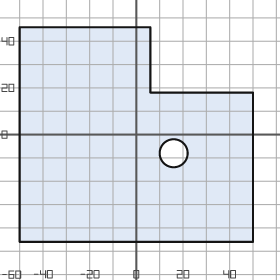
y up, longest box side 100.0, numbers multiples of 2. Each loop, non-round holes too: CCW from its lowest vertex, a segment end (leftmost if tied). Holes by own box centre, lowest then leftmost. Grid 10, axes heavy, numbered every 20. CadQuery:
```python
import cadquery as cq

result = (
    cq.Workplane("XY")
    .moveTo(-50.0, -46.0)
    .lineTo(50.0, -46.0)
    .lineTo(50.0, 18.0)
    .lineTo(6.0, 18.0)
    .lineTo(6.0, 46.0)
    .lineTo(-50.0, 46.0)
    .close()
    .moveTo(16.0, -8.0)
    .circle(6.0)
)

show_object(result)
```